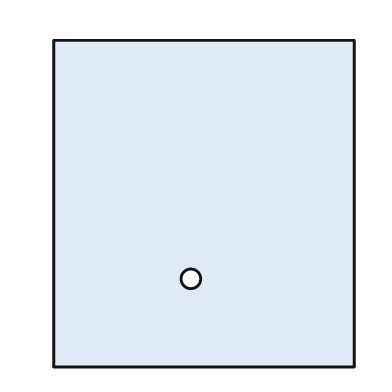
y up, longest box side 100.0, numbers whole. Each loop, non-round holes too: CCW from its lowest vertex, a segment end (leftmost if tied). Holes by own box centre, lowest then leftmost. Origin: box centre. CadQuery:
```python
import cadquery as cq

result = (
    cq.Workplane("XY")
    .moveTo(-46.0, -50.0)
    .lineTo(46.0, -50.0)
    .lineTo(46.0, 50.0)
    .lineTo(-46.0, 50.0)
    .close()
    .moveTo(-4.0, -23.0)
    .circle(3.0)
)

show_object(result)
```